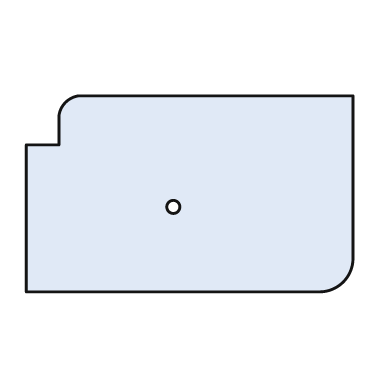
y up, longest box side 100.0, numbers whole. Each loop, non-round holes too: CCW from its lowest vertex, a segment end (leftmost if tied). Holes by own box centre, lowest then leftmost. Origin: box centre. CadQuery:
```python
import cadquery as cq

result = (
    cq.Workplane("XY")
    .moveTo(-50.0, -30.0)
    .lineTo(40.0, -30.0)
    .threePointArc((47.0, -27.0), (50.0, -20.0))
    .lineTo(50.0, 30.0)
    .lineTo(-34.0, 30.0)
    .threePointArc((-38.0, 28.0), (-40.0, 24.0))
    .lineTo(-40.0, 15.0)
    .lineTo(-50.0, 15.0)
    .close()
    .moveTo(-5.0, -4.0)
    .circle(2.0)
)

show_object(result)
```